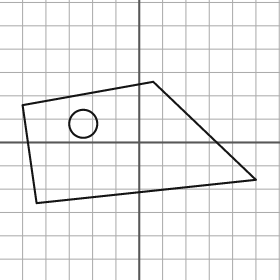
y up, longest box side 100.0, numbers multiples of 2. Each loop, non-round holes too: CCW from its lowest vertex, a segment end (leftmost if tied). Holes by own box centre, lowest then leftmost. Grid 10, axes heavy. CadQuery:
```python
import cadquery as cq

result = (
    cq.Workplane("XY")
    .moveTo(-44.0, -26.0)
    .lineTo(50.0, -16.0)
    .lineTo(6.0, 26.0)
    .lineTo(-50.0, 16.0)
    .close()
    .moveTo(-24.0, 8.0)
    .circle(6.0)
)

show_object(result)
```